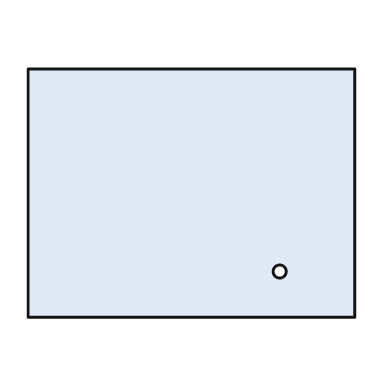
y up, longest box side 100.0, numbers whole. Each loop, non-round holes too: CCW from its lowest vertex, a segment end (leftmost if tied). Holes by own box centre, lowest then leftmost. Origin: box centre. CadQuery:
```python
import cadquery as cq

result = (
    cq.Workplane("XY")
    .moveTo(-50.0, -38.0)
    .lineTo(50.0, -38.0)
    .lineTo(50.0, 38.0)
    .lineTo(-50.0, 38.0)
    .close()
    .moveTo(27.0, -24.0)
    .circle(2.0)
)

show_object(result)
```